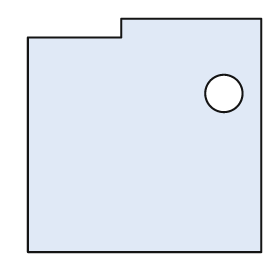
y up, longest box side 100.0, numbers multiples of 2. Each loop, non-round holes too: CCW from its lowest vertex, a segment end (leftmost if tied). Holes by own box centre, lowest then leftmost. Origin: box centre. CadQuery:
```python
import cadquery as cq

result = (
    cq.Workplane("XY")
    .moveTo(-50.0, -50.0)
    .lineTo(50.0, -50.0)
    .lineTo(50.0, 50.0)
    .lineTo(-10.0, 50.0)
    .lineTo(-10.0, 42.0)
    .lineTo(-50.0, 42.0)
    .close()
    .moveTo(34.0, 18.0)
    .circle(8.0)
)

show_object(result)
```